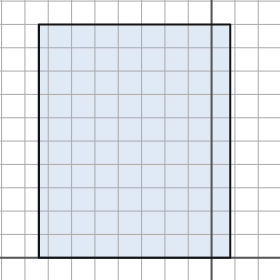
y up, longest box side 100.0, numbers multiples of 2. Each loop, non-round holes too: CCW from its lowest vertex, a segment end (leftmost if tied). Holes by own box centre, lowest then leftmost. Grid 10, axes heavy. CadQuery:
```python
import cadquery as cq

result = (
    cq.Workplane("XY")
    .moveTo(-74.0, 0.0)
    .lineTo(8.0, 0.0)
    .lineTo(8.0, 100.0)
    .lineTo(-74.0, 100.0)
    .close()
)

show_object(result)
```